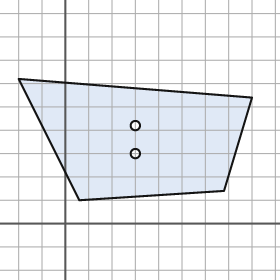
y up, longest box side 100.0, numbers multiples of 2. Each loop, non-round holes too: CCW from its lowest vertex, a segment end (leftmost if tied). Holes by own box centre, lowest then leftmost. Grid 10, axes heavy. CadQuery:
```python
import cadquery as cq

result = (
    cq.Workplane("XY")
    .moveTo(6.0, 10.0)
    .lineTo(68.0, 14.0)
    .lineTo(80.0, 54.0)
    .lineTo(-20.0, 62.0)
    .close()
    .moveTo(30.0, 30.0)
    .circle(2.0)
    .moveTo(30.0, 42.0)
    .circle(2.0)
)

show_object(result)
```